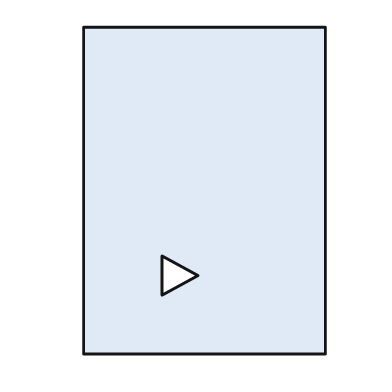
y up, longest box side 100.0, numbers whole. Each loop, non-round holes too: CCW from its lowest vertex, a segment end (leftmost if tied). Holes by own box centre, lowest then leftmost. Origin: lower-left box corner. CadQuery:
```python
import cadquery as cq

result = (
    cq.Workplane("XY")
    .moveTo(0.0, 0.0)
    .lineTo(74.0, 0.0)
    .lineTo(74.0, 100.0)
    .lineTo(0.0, 100.0)
    .close()
    .moveTo(24.0, 18.0)
    .lineTo(35.0, 24.0)
    .lineTo(24.0, 30.0)
    .close()
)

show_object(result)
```